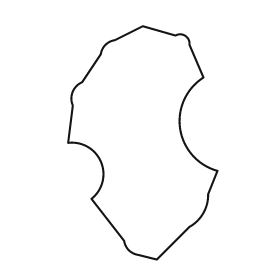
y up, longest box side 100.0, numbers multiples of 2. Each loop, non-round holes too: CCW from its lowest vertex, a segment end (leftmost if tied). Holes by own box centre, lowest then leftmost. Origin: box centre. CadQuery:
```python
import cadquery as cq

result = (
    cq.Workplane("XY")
    .moveTo(6.0, -50.0)
    .lineTo(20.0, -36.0)
    .threePointArc((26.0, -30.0), (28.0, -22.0))
    .lineTo(32.0, -12.0)
    .threePointArc((16.0, 6.0), (26.0, 28.0))
    .lineTo(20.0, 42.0)
    .threePointArc((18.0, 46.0), (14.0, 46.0))
    .lineTo(0.0, 50.0)
    .lineTo(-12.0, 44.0)
    .threePointArc((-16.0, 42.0), (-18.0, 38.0))
    .lineTo(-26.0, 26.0)
    .threePointArc((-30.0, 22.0), (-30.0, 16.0))
    .lineTo(-32.0, 0.0)
    .threePointArc((-18.0, -8.0), (-22.0, -24.0))
    .lineTo(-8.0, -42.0)
    .threePointArc((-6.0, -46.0), (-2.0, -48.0))
    .close()
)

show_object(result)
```